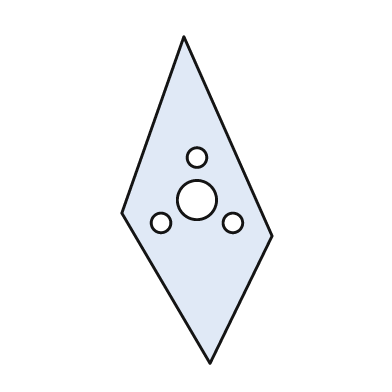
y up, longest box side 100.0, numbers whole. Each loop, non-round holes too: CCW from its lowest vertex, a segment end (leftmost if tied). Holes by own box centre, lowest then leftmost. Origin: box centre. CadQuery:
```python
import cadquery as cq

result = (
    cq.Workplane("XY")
    .moveTo(4.0, -50.0)
    .lineTo(23.0, -11.0)
    .lineTo(-4.0, 50.0)
    .lineTo(-23.0, -4.0)
    .close()
    .moveTo(-11.0, -7.0)
    .circle(3.0)
    .moveTo(11.0, -7.0)
    .circle(3.0)
    .moveTo(0.0, 0.0)
    .circle(6.0)
    .moveTo(0.0, 13.0)
    .circle(3.0)
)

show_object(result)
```